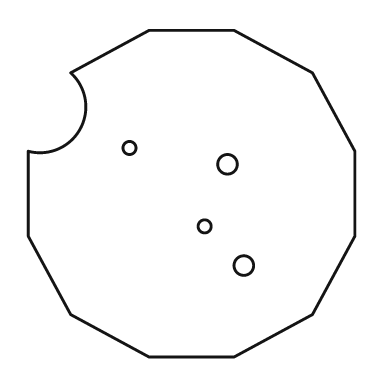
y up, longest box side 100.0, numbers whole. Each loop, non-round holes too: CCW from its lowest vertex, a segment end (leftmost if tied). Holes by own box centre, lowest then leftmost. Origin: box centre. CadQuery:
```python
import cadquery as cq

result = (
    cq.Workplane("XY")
    .moveTo(-13.0, -50.0)
    .lineTo(13.0, -50.0)
    .lineTo(37.0, -37.0)
    .lineTo(50.0, -13.0)
    .lineTo(50.0, 13.0)
    .lineTo(37.0, 37.0)
    .lineTo(13.0, 50.0)
    .lineTo(-13.0, 50.0)
    .lineTo(-37.0, 37.0)
    .threePointArc((-34.0, 20.0), (-50.0, 13.0))
    .lineTo(-50.0, -13.0)
    .lineTo(-37.0, -37.0)
    .close()
    .moveTo(16.0, -22.0)
    .circle(3.0)
    .moveTo(4.0, -10.0)
    .circle(2.0)
    .moveTo(11.0, 9.0)
    .circle(3.0)
    .moveTo(-19.0, 14.0)
    .circle(2.0)
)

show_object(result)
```